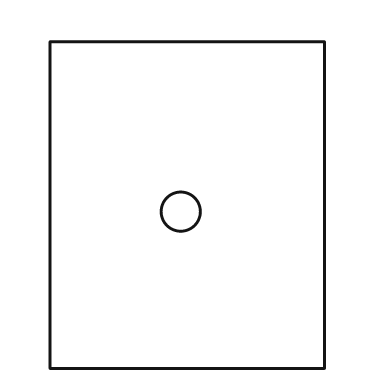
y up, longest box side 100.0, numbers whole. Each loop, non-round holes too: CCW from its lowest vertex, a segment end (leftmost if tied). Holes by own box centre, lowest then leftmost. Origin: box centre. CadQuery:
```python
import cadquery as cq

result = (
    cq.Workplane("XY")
    .moveTo(-42.0, -50.0)
    .lineTo(42.0, -50.0)
    .lineTo(42.0, 50.0)
    .lineTo(-42.0, 50.0)
    .close()
    .moveTo(-2.0, -2.0)
    .circle(6.0)
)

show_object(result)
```